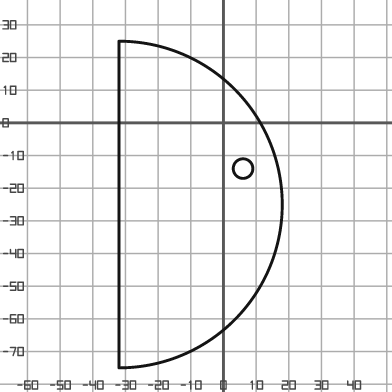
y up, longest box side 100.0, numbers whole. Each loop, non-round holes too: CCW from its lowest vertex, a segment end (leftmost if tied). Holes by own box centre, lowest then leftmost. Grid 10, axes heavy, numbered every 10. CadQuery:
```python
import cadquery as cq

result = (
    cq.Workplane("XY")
    .moveTo(-32.0, -75.0)
    .threePointArc((18.0, -25.0), (-32.0, 25.0))
    .close()
    .moveTo(6.0, -14.0)
    .circle(3.0)
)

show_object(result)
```